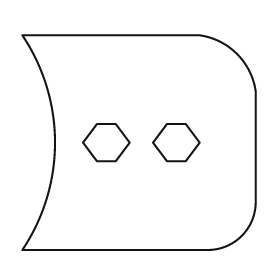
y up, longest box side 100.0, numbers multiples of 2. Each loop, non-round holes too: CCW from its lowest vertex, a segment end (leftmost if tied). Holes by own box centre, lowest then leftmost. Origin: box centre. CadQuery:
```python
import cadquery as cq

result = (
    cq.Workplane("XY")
    .moveTo(-50.0, -46.0)
    .lineTo(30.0, -46.0)
    .threePointArc((44.0, -40.0), (50.0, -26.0))
    .lineTo(50.0, 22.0)
    .threePointArc((42.0, 38.0), (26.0, 46.0))
    .lineTo(-50.0, 46.0)
    .threePointArc((-36.0, 0.0), (-50.0, -46.0))
    .close()
    .moveTo(-18.0, -8.0)
    .lineTo(-10.0, -8.0)
    .lineTo(-4.0, 0.0)
    .lineTo(-10.0, 8.0)
    .lineTo(-18.0, 8.0)
    .lineTo(-24.0, 0.0)
    .close()
    .moveTo(12.0, -8.0)
    .lineTo(20.0, -8.0)
    .lineTo(26.0, 0.0)
    .lineTo(20.0, 8.0)
    .lineTo(12.0, 8.0)
    .lineTo(6.0, 0.0)
    .close()
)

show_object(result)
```